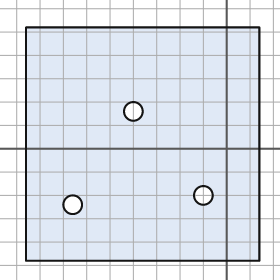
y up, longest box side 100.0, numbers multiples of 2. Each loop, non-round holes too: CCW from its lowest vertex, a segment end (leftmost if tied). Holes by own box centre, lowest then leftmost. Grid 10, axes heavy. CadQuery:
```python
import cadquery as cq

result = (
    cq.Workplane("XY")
    .moveTo(-86.0, -48.0)
    .lineTo(14.0, -48.0)
    .lineTo(14.0, 52.0)
    .lineTo(-86.0, 52.0)
    .close()
    .moveTo(-66.0, -24.0)
    .circle(4.0)
    .moveTo(-10.0, -20.0)
    .circle(4.0)
    .moveTo(-40.0, 16.0)
    .circle(4.0)
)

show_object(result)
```